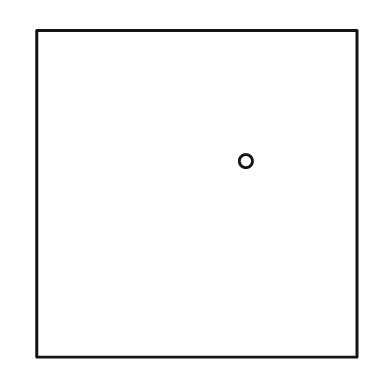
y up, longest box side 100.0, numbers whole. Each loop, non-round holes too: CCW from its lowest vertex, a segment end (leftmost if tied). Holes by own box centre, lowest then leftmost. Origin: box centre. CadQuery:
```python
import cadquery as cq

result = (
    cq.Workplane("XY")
    .moveTo(-49.0, -50.0)
    .lineTo(49.0, -50.0)
    .lineTo(49.0, 50.0)
    .lineTo(-49.0, 50.0)
    .close()
    .moveTo(15.0, 10.0)
    .circle(2.0)
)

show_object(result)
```